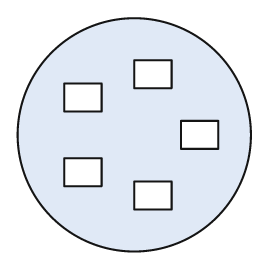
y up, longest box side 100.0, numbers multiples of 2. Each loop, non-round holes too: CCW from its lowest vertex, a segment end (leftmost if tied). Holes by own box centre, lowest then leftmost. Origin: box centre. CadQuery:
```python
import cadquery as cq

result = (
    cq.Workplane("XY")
    .moveTo(0.0, 0.0)
    .circle(50.0)
    .moveTo(0.0, -32.0)
    .lineTo(16.0, -32.0)
    .lineTo(16.0, -20.0)
    .lineTo(0.0, -20.0)
    .close()
    .moveTo(-30.0, -22.0)
    .lineTo(-14.0, -22.0)
    .lineTo(-14.0, -10.0)
    .lineTo(-30.0, -10.0)
    .close()
    .moveTo(20.0, -6.0)
    .lineTo(36.0, -6.0)
    .lineTo(36.0, 6.0)
    .lineTo(20.0, 6.0)
    .close()
    .moveTo(-30.0, 10.0)
    .lineTo(-14.0, 10.0)
    .lineTo(-14.0, 22.0)
    .lineTo(-30.0, 22.0)
    .close()
    .moveTo(0.0, 20.0)
    .lineTo(16.0, 20.0)
    .lineTo(16.0, 32.0)
    .lineTo(0.0, 32.0)
    .close()
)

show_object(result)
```